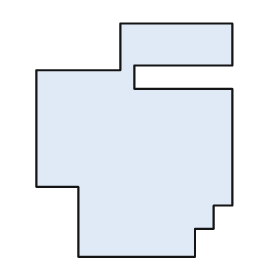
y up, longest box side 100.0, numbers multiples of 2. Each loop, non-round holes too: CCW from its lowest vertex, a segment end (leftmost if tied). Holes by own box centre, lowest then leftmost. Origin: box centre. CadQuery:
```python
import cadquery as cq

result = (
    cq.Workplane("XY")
    .moveTo(-24.0, -50.0)
    .lineTo(26.0, -50.0)
    .lineTo(26.0, -38.0)
    .lineTo(34.0, -38.0)
    .lineTo(34.0, -28.0)
    .lineTo(42.0, -28.0)
    .lineTo(42.0, 22.0)
    .lineTo(0.0, 22.0)
    .lineTo(0.0, 32.0)
    .lineTo(42.0, 32.0)
    .lineTo(42.0, 50.0)
    .lineTo(-6.0, 50.0)
    .lineTo(-6.0, 30.0)
    .lineTo(-42.0, 30.0)
    .lineTo(-42.0, -20.0)
    .lineTo(-24.0, -20.0)
    .close()
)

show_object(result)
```